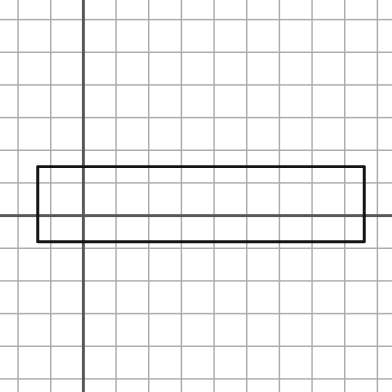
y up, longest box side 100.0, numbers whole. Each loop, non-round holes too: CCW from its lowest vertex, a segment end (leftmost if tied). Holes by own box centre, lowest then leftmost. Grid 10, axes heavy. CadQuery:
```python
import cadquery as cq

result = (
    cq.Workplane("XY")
    .moveTo(-14.0, -8.0)
    .lineTo(86.0, -8.0)
    .lineTo(86.0, 15.0)
    .lineTo(-14.0, 15.0)
    .close()
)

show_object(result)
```